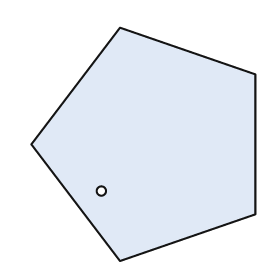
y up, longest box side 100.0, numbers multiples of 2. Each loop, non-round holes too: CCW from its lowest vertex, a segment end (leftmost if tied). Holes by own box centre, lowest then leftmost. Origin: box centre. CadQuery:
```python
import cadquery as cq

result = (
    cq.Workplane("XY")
    .moveTo(-10.0, -50.0)
    .lineTo(48.0, -30.0)
    .lineTo(48.0, 30.0)
    .lineTo(-10.0, 50.0)
    .lineTo(-48.0, 0.0)
    .close()
    .moveTo(-18.0, -20.0)
    .circle(2.0)
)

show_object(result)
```